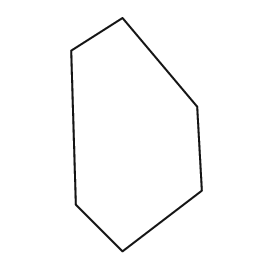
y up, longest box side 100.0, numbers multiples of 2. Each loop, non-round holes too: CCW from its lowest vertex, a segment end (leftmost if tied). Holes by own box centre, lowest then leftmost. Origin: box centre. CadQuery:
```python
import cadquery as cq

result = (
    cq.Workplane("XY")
    .moveTo(-6.0, -50.0)
    .lineTo(28.0, -24.0)
    .lineTo(26.0, 12.0)
    .lineTo(-6.0, 50.0)
    .lineTo(-28.0, 36.0)
    .lineTo(-26.0, -30.0)
    .close()
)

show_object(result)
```